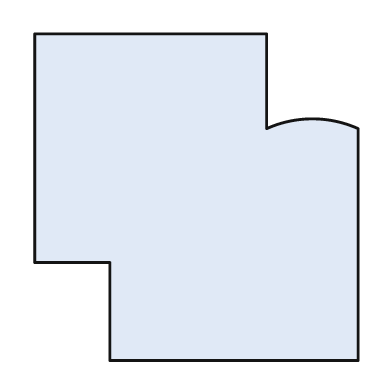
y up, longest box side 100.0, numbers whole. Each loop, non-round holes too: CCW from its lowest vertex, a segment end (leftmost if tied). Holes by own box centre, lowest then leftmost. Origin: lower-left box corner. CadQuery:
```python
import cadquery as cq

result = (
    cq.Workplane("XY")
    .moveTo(23.0, 0.0)
    .lineTo(99.0, 0.0)
    .lineTo(99.0, 71.0)
    .threePointArc((85.0, 74.0), (71.0, 71.0))
    .lineTo(71.0, 100.0)
    .lineTo(0.0, 100.0)
    .lineTo(0.0, 30.0)
    .lineTo(23.0, 30.0)
    .close()
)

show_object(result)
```